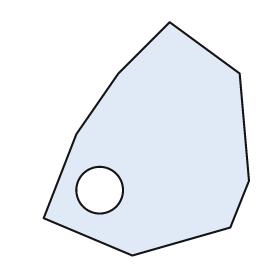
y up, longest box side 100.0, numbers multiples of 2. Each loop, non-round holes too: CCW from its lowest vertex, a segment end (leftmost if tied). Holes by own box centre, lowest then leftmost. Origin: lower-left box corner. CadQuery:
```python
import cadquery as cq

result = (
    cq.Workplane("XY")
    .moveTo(38.0, 0.0)
    .lineTo(80.0, 12.0)
    .lineTo(88.0, 32.0)
    .lineTo(84.0, 78.0)
    .lineTo(54.0, 100.0)
    .lineTo(32.0, 78.0)
    .lineTo(14.0, 52.0)
    .lineTo(0.0, 16.0)
    .close()
    .moveTo(24.0, 28.0)
    .circle(10.0)
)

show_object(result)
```